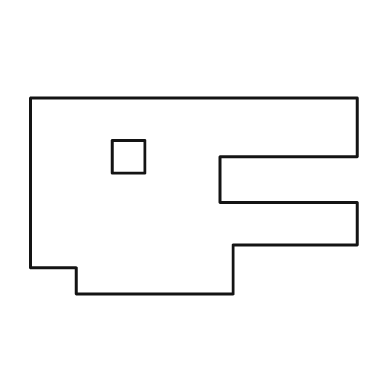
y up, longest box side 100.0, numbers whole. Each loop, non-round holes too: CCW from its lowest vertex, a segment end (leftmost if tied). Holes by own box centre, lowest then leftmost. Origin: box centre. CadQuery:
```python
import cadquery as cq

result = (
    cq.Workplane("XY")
    .moveTo(-36.0, -30.0)
    .lineTo(12.0, -30.0)
    .lineTo(12.0, -15.0)
    .lineTo(50.0, -15.0)
    .lineTo(50.0, -2.0)
    .lineTo(8.0, -2.0)
    .lineTo(8.0, 12.0)
    .lineTo(50.0, 12.0)
    .lineTo(50.0, 30.0)
    .lineTo(-50.0, 30.0)
    .lineTo(-50.0, -22.0)
    .lineTo(-36.0, -22.0)
    .close()
    .moveTo(-25.0, 7.0)
    .lineTo(-15.0, 7.0)
    .lineTo(-15.0, 17.0)
    .lineTo(-25.0, 17.0)
    .close()
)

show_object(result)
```